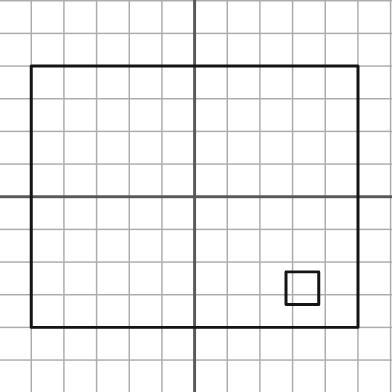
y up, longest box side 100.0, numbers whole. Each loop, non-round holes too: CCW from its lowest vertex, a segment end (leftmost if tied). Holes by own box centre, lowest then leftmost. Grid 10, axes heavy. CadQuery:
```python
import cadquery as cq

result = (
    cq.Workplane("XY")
    .moveTo(-50.0, -40.0)
    .lineTo(50.0, -40.0)
    .lineTo(50.0, 40.0)
    .lineTo(-50.0, 40.0)
    .close()
    .moveTo(28.0, -33.0)
    .lineTo(38.0, -33.0)
    .lineTo(38.0, -23.0)
    .lineTo(28.0, -23.0)
    .close()
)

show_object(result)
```